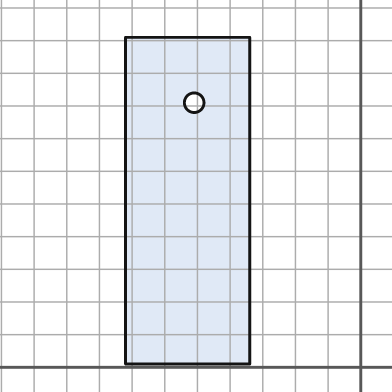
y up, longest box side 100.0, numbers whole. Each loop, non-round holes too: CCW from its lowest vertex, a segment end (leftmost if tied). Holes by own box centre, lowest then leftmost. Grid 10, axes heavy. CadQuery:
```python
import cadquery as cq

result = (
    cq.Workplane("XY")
    .moveTo(-72.0, 1.0)
    .lineTo(-34.0, 1.0)
    .lineTo(-34.0, 101.0)
    .lineTo(-72.0, 101.0)
    .close()
    .moveTo(-51.0, 81.0)
    .circle(3.0)
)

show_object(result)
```